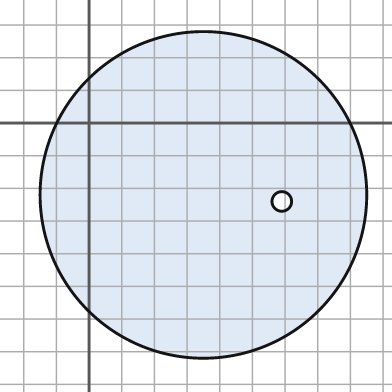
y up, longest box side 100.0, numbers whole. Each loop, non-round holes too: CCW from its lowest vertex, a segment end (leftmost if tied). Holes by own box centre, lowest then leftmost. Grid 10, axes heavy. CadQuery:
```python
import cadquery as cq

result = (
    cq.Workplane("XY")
    .moveTo(35.0, -22.0)
    .circle(50.0)
    .moveTo(59.0, -24.0)
    .circle(3.0)
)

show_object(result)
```